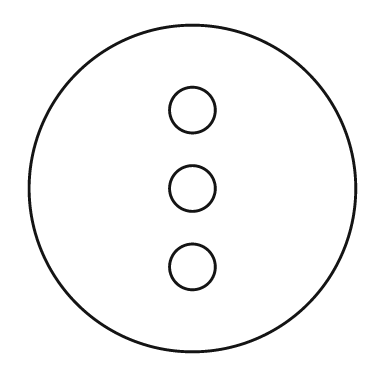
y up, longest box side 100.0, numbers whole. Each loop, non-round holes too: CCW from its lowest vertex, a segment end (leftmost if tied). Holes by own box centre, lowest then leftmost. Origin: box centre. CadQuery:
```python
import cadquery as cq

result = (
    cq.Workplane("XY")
    .moveTo(0.0, 0.0)
    .circle(50.0)
    .moveTo(0.0, -24.0)
    .circle(7.0)
    .moveTo(0.0, 0.0)
    .circle(7.0)
    .moveTo(0.0, 24.0)
    .circle(7.0)
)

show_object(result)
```